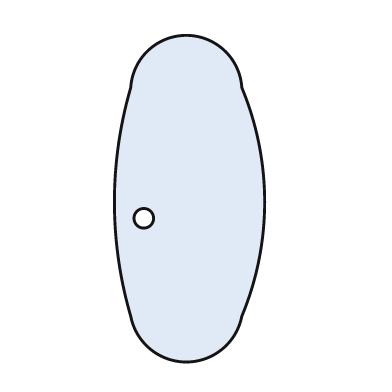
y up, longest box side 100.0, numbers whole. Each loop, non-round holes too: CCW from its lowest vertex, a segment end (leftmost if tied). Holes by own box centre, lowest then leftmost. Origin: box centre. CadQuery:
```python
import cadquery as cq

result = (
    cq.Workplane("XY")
    .moveTo(-18.0, -36.0)
    .threePointArc((-1.0, -50.0), (16.0, -36.0))
    .threePointArc((23.0, -1.0), (16.0, 34.0))
    .threePointArc((-1.0, 50.0), (-18.0, 34.0))
    .threePointArc((-23.0, -1.0), (-18.0, -36.0))
    .close()
    .moveTo(-14.0, -6.0)
    .circle(3.0)
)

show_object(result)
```